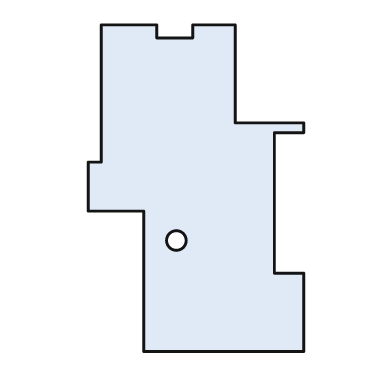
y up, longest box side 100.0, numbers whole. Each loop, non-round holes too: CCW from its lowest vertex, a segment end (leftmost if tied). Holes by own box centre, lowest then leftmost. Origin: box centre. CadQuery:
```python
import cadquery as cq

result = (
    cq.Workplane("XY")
    .moveTo(-16.0, -50.0)
    .lineTo(33.0, -50.0)
    .lineTo(33.0, -26.0)
    .lineTo(24.0, -26.0)
    .lineTo(24.0, 17.0)
    .lineTo(33.0, 17.0)
    .lineTo(33.0, 20.0)
    .lineTo(12.0, 20.0)
    .lineTo(12.0, 50.0)
    .lineTo(-1.0, 50.0)
    .lineTo(-1.0, 46.0)
    .lineTo(-12.0, 46.0)
    .lineTo(-12.0, 50.0)
    .lineTo(-29.0, 50.0)
    .lineTo(-29.0, 8.0)
    .lineTo(-33.0, 8.0)
    .lineTo(-33.0, -7.0)
    .lineTo(-16.0, -7.0)
    .close()
    .moveTo(-6.0, -16.0)
    .circle(3.0)
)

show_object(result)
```